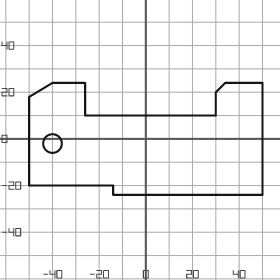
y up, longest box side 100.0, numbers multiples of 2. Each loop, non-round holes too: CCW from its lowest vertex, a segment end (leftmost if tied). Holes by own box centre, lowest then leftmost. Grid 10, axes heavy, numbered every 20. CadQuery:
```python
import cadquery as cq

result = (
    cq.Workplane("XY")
    .moveTo(-14.0, -24.0)
    .lineTo(50.0, -24.0)
    .lineTo(50.0, 24.0)
    .lineTo(34.0, 24.0)
    .lineTo(30.0, 20.0)
    .lineTo(30.0, 10.0)
    .lineTo(-26.0, 10.0)
    .lineTo(-26.0, 24.0)
    .lineTo(-40.0, 24.0)
    .lineTo(-50.0, 18.0)
    .lineTo(-50.0, -20.0)
    .lineTo(-14.0, -20.0)
    .close()
    .moveTo(-40.0, -2.0)
    .circle(4.0)
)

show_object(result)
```